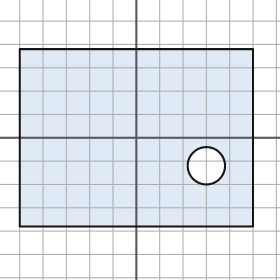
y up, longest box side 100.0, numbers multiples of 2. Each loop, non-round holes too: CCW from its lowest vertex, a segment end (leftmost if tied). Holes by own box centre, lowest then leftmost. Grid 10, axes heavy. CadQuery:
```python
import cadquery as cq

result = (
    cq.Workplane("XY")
    .moveTo(-50.0, -38.0)
    .lineTo(50.0, -38.0)
    .lineTo(50.0, 38.0)
    .lineTo(-50.0, 38.0)
    .close()
    .moveTo(30.0, -12.0)
    .circle(8.0)
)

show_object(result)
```